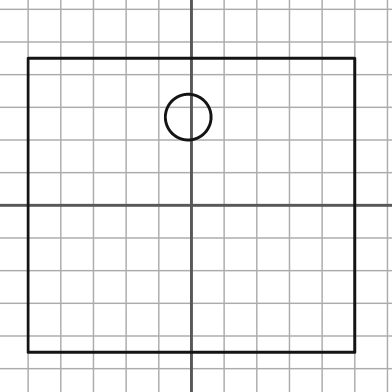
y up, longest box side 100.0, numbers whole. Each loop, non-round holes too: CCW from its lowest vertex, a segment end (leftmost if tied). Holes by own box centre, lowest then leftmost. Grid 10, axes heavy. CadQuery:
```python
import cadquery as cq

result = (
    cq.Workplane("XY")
    .moveTo(-50.0, -45.0)
    .lineTo(50.0, -45.0)
    .lineTo(50.0, 45.0)
    .lineTo(-50.0, 45.0)
    .close()
    .moveTo(-1.0, 27.0)
    .circle(7.0)
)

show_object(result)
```